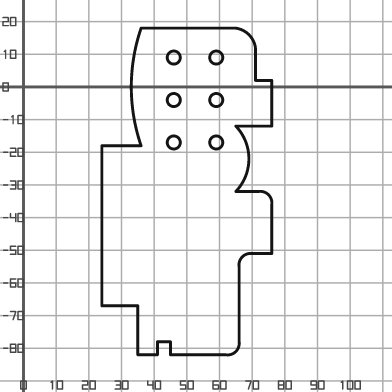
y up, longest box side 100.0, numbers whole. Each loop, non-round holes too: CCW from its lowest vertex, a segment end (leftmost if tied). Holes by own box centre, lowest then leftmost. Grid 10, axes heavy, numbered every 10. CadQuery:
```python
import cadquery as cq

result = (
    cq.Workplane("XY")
    .moveTo(35.0, -82.0)
    .lineTo(41.0, -82.0)
    .lineTo(41.0, -78.0)
    .lineTo(45.0, -78.0)
    .lineTo(45.0, -82.0)
    .lineTo(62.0, -82.0)
    .threePointArc((65.0, -81.0), (66.0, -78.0))
    .lineTo(66.0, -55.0)
    .threePointArc((67.0, -52.0), (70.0, -51.0))
    .lineTo(76.0, -51.0)
    .lineTo(76.0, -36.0)
    .threePointArc((75.0, -33.0), (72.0, -32.0))
    .lineTo(65.0, -32.0)
    .threePointArc((69.0, -22.0), (65.0, -12.0))
    .lineTo(76.0, -12.0)
    .lineTo(76.0, 2.0)
    .lineTo(71.0, 2.0)
    .lineTo(71.0, 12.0)
    .threePointArc((69.0, 16.0), (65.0, 18.0))
    .lineTo(36.0, 18.0)
    .threePointArc((33.0, 0.0), (36.0, -18.0))
    .lineTo(24.0, -18.0)
    .lineTo(24.0, -67.0)
    .lineTo(35.0, -67.0)
    .close()
    .moveTo(46.0, -17.0)
    .circle(2.0)
    .moveTo(59.0, -17.0)
    .circle(2.0)
    .moveTo(46.0, -4.0)
    .circle(2.0)
    .moveTo(59.0, -4.0)
    .circle(2.0)
    .moveTo(46.0, 9.0)
    .circle(2.0)
    .moveTo(59.0, 9.0)
    .circle(2.0)
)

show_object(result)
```